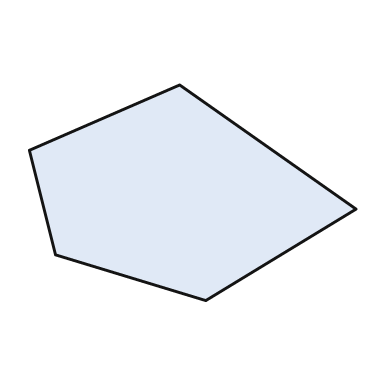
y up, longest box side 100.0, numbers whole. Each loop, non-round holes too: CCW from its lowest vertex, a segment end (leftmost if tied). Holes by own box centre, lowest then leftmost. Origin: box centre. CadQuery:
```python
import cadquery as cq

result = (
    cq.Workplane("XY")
    .moveTo(4.0, -33.0)
    .lineTo(50.0, -5.0)
    .lineTo(-4.0, 33.0)
    .lineTo(-50.0, 13.0)
    .lineTo(-42.0, -19.0)
    .close()
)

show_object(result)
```